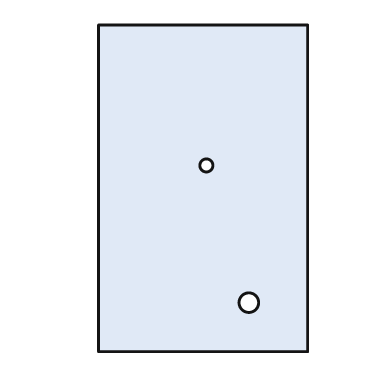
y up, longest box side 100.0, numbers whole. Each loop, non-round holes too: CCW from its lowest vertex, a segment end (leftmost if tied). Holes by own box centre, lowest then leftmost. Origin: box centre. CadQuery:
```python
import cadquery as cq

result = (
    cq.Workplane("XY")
    .moveTo(-32.0, -50.0)
    .lineTo(32.0, -50.0)
    .lineTo(32.0, 50.0)
    .lineTo(-32.0, 50.0)
    .close()
    .moveTo(14.0, -35.0)
    .circle(3.0)
    .moveTo(1.0, 7.0)
    .circle(2.0)
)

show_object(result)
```